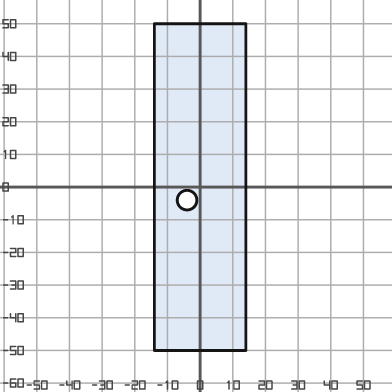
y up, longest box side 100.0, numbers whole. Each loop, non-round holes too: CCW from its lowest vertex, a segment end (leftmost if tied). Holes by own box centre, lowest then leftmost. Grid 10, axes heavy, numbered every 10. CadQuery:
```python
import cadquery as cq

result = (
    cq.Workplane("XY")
    .moveTo(-14.0, -50.0)
    .lineTo(14.0, -50.0)
    .lineTo(14.0, 50.0)
    .lineTo(-14.0, 50.0)
    .close()
    .moveTo(-4.0, -4.0)
    .circle(3.0)
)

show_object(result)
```